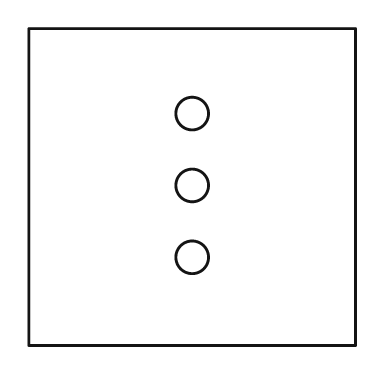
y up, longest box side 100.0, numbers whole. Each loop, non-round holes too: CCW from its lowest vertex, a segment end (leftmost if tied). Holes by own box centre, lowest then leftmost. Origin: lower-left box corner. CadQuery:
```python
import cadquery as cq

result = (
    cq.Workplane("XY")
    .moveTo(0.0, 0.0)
    .lineTo(100.0, 0.0)
    .lineTo(100.0, 97.0)
    .lineTo(0.0, 97.0)
    .close()
    .moveTo(50.0, 27.0)
    .circle(5.0)
    .moveTo(50.0, 49.0)
    .circle(5.0)
    .moveTo(50.0, 71.0)
    .circle(5.0)
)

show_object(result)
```